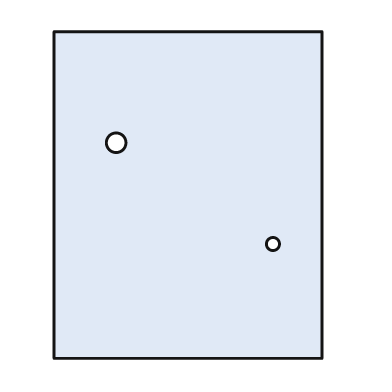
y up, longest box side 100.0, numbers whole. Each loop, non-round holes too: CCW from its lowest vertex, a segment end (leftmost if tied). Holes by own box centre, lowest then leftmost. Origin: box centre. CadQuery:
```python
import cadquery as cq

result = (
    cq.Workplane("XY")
    .moveTo(-41.0, -50.0)
    .lineTo(41.0, -50.0)
    .lineTo(41.0, 50.0)
    .lineTo(-41.0, 50.0)
    .close()
    .moveTo(26.0, -15.0)
    .circle(2.0)
    .moveTo(-22.0, 16.0)
    .circle(3.0)
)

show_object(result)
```